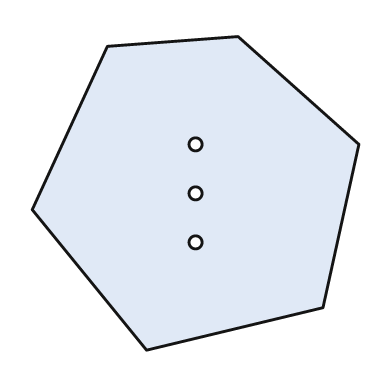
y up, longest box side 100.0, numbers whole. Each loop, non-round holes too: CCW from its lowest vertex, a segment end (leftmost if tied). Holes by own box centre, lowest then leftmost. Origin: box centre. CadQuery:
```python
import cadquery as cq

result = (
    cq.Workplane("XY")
    .moveTo(-15.0, -48.0)
    .lineTo(39.0, -35.0)
    .lineTo(50.0, 15.0)
    .lineTo(13.0, 48.0)
    .lineTo(-27.0, 45.0)
    .lineTo(-50.0, -5.0)
    .close()
    .moveTo(0.0, -15.0)
    .circle(2.0)
    .moveTo(0.0, 0.0)
    .circle(2.0)
    .moveTo(0.0, 15.0)
    .circle(2.0)
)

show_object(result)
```